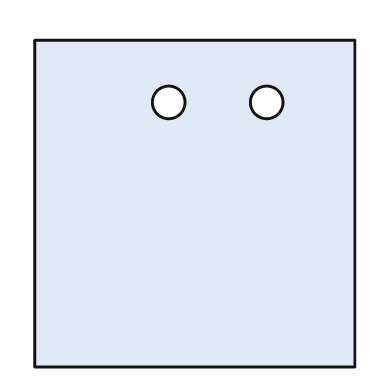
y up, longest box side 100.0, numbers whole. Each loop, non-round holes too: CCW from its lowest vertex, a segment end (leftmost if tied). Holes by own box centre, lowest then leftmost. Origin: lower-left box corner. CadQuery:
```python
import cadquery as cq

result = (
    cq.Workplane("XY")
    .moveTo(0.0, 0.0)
    .lineTo(98.0, 0.0)
    .lineTo(98.0, 100.0)
    .lineTo(0.0, 100.0)
    .close()
    .moveTo(41.0, 81.0)
    .circle(5.0)
    .moveTo(71.0, 81.0)
    .circle(5.0)
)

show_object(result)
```